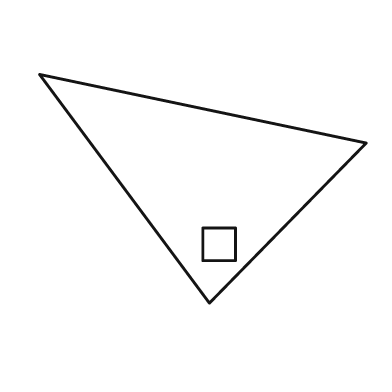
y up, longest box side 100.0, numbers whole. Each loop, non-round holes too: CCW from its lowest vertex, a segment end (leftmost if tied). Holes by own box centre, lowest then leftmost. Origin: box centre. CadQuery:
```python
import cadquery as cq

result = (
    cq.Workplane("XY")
    .moveTo(2.0, -35.0)
    .lineTo(50.0, 14.0)
    .lineTo(-50.0, 35.0)
    .close()
    .moveTo(0.0, -22.0)
    .lineTo(10.0, -22.0)
    .lineTo(10.0, -12.0)
    .lineTo(0.0, -12.0)
    .close()
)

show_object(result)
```